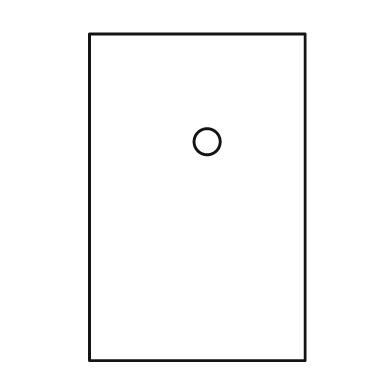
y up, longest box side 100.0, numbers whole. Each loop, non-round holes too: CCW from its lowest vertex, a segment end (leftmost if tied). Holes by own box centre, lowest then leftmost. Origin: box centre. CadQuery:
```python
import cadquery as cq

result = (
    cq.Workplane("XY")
    .moveTo(-33.0, -50.0)
    .lineTo(33.0, -50.0)
    .lineTo(33.0, 50.0)
    .lineTo(-33.0, 50.0)
    .close()
    .moveTo(3.0, 17.0)
    .circle(4.0)
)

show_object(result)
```